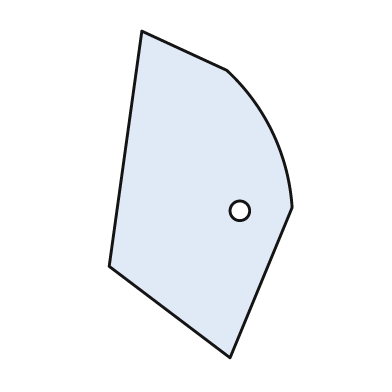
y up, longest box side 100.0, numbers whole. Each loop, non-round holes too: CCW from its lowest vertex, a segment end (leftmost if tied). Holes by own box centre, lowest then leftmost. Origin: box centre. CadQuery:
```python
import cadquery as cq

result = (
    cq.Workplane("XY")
    .moveTo(9.0, -50.0)
    .lineTo(28.0, -4.0)
    .threePointArc((22.0, 19.0), (8.0, 38.0))
    .lineTo(-18.0, 50.0)
    .lineTo(-28.0, -22.0)
    .close()
    .moveTo(12.0, -5.0)
    .circle(3.0)
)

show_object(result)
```